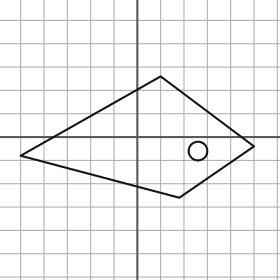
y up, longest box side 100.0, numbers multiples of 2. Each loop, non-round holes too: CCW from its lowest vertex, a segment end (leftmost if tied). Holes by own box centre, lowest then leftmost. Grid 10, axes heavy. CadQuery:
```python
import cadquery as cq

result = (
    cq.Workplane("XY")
    .moveTo(18.0, -26.0)
    .lineTo(50.0, -4.0)
    .lineTo(10.0, 26.0)
    .lineTo(-50.0, -8.0)
    .close()
    .moveTo(26.0, -6.0)
    .circle(4.0)
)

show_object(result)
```